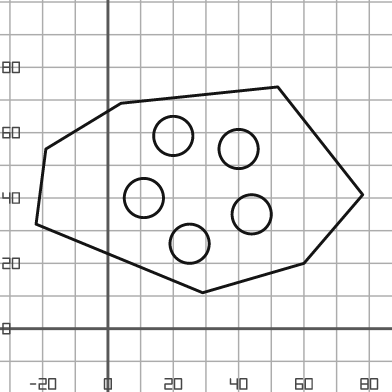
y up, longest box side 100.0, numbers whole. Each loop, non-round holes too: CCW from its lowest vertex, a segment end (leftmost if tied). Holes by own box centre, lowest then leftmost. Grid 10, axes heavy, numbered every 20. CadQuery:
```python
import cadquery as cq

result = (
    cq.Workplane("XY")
    .moveTo(29.0, 11.0)
    .lineTo(60.0, 20.0)
    .lineTo(78.0, 41.0)
    .lineTo(52.0, 74.0)
    .lineTo(4.0, 69.0)
    .lineTo(-19.0, 55.0)
    .lineTo(-22.0, 32.0)
    .close()
    .moveTo(25.0, 26.0)
    .circle(6.0)
    .moveTo(44.0, 35.0)
    .circle(6.0)
    .moveTo(11.0, 40.0)
    .circle(6.0)
    .moveTo(40.0, 55.0)
    .circle(6.0)
    .moveTo(20.0, 59.0)
    .circle(6.0)
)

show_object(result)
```